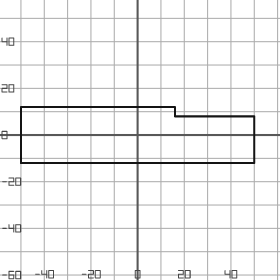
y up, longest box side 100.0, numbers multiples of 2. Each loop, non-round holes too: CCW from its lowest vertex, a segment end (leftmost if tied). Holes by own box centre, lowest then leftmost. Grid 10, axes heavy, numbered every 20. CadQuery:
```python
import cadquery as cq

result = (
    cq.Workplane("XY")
    .moveTo(-50.0, -12.0)
    .lineTo(50.0, -12.0)
    .lineTo(50.0, 8.0)
    .lineTo(16.0, 8.0)
    .lineTo(16.0, 12.0)
    .lineTo(-50.0, 12.0)
    .close()
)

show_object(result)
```